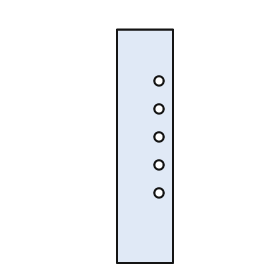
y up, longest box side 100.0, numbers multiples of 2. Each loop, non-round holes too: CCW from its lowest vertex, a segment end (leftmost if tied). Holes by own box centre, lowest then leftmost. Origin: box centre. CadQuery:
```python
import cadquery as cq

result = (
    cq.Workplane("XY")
    .moveTo(-12.0, -50.0)
    .lineTo(12.0, -50.0)
    .lineTo(12.0, 50.0)
    .lineTo(-12.0, 50.0)
    .close()
    .moveTo(6.0, -20.0)
    .circle(2.0)
    .moveTo(6.0, -8.0)
    .circle(2.0)
    .moveTo(6.0, 4.0)
    .circle(2.0)
    .moveTo(6.0, 16.0)
    .circle(2.0)
    .moveTo(6.0, 28.0)
    .circle(2.0)
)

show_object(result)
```